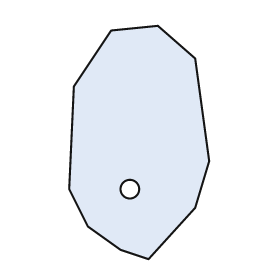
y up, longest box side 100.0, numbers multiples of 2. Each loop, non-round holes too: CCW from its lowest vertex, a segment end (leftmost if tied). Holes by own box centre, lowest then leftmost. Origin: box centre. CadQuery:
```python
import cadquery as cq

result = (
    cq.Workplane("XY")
    .moveTo(4.0, -50.0)
    .lineTo(24.0, -28.0)
    .lineTo(30.0, -8.0)
    .lineTo(24.0, 36.0)
    .lineTo(8.0, 50.0)
    .lineTo(-12.0, 48.0)
    .lineTo(-28.0, 24.0)
    .lineTo(-30.0, -20.0)
    .lineTo(-22.0, -36.0)
    .lineTo(-8.0, -46.0)
    .close()
    .moveTo(-4.0, -20.0)
    .circle(4.0)
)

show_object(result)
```